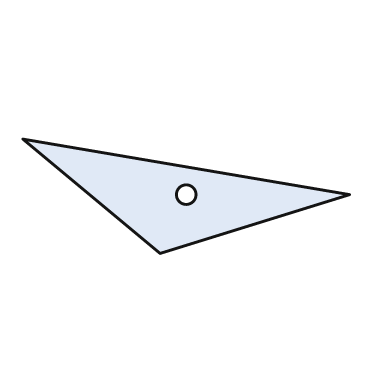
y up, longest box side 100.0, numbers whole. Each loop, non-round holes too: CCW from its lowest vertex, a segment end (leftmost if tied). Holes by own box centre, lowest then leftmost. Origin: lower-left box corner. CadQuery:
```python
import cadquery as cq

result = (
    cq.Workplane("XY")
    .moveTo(42.0, 0.0)
    .lineTo(100.0, 18.0)
    .lineTo(0.0, 35.0)
    .close()
    .moveTo(50.0, 18.0)
    .circle(3.0)
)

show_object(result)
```